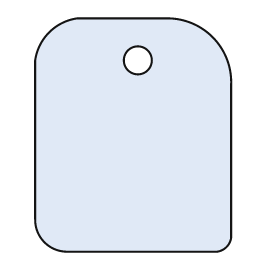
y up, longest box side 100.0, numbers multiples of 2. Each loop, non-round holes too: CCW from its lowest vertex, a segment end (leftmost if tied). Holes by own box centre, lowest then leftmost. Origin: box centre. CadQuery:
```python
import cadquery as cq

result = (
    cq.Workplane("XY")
    .moveTo(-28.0, -50.0)
    .lineTo(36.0, -50.0)
    .threePointArc((40.0, -48.0), (42.0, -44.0))
    .lineTo(42.0, 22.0)
    .threePointArc((34.0, 42.0), (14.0, 50.0))
    .lineTo(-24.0, 50.0)
    .threePointArc((-36.0, 44.0), (-42.0, 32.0))
    .lineTo(-42.0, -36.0)
    .threePointArc((-38.0, -46.0), (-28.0, -50.0))
    .close()
    .moveTo(2.0, 32.0)
    .circle(6.0)
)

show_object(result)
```